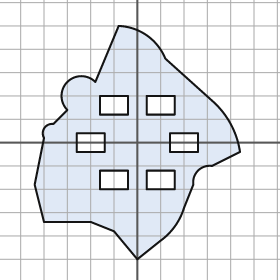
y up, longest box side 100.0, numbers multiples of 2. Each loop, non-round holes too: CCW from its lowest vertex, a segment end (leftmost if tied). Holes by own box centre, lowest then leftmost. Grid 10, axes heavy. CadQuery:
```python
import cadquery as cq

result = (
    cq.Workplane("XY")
    .moveTo(0.0, -50.0)
    .lineTo(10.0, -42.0)
    .threePointArc((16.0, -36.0), (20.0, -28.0))
    .lineTo(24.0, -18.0)
    .threePointArc((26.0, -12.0), (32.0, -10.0))
    .lineTo(44.0, -4.0)
    .threePointArc((40.0, 8.0), (32.0, 18.0))
    .lineTo(12.0, 36.0)
    .threePointArc((4.0, 46.0), (-8.0, 50.0))
    .lineTo(-18.0, 26.0)
    .threePointArc((-30.0, 26.0), (-30.0, 14.0))
    .lineTo(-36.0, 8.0)
    .threePointArc((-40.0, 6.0), (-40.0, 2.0))
    .lineTo(-44.0, -18.0)
    .lineTo(-40.0, -34.0)
    .lineTo(-20.0, -34.0)
    .lineTo(-10.0, -38.0)
    .close()
    .moveTo(-16.0, -20.0)
    .lineTo(-4.0, -20.0)
    .lineTo(-4.0, -12.0)
    .lineTo(-16.0, -12.0)
    .close()
    .moveTo(4.0, -20.0)
    .lineTo(16.0, -20.0)
    .lineTo(16.0, -12.0)
    .lineTo(4.0, -12.0)
    .close()
    .moveTo(-26.0, -4.0)
    .lineTo(-14.0, -4.0)
    .lineTo(-14.0, 4.0)
    .lineTo(-26.0, 4.0)
    .close()
    .moveTo(14.0, -4.0)
    .lineTo(26.0, -4.0)
    .lineTo(26.0, 4.0)
    .lineTo(14.0, 4.0)
    .close()
    .moveTo(-16.0, 12.0)
    .lineTo(-4.0, 12.0)
    .lineTo(-4.0, 20.0)
    .lineTo(-16.0, 20.0)
    .close()
    .moveTo(4.0, 12.0)
    .lineTo(16.0, 12.0)
    .lineTo(16.0, 20.0)
    .lineTo(4.0, 20.0)
    .close()
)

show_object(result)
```